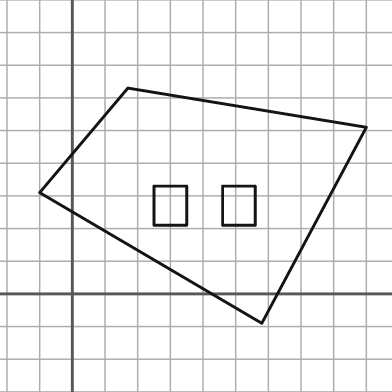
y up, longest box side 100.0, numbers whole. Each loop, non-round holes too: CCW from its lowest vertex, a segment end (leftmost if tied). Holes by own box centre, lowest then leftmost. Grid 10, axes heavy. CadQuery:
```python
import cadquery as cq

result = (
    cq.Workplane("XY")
    .moveTo(58.0, -9.0)
    .lineTo(90.0, 51.0)
    .lineTo(17.0, 63.0)
    .lineTo(-10.0, 31.0)
    .close()
    .moveTo(25.0, 21.0)
    .lineTo(35.0, 21.0)
    .lineTo(35.0, 33.0)
    .lineTo(25.0, 33.0)
    .close()
    .moveTo(46.0, 21.0)
    .lineTo(56.0, 21.0)
    .lineTo(56.0, 33.0)
    .lineTo(46.0, 33.0)
    .close()
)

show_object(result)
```